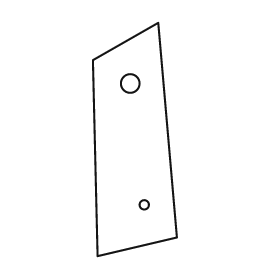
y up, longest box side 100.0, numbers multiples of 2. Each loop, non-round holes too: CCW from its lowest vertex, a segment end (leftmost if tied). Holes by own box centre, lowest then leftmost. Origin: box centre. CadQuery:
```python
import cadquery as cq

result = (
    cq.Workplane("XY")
    .moveTo(-16.0, -50.0)
    .lineTo(18.0, -42.0)
    .lineTo(10.0, 50.0)
    .lineTo(-18.0, 34.0)
    .close()
    .moveTo(4.0, -28.0)
    .circle(2.0)
    .moveTo(-2.0, 24.0)
    .circle(4.0)
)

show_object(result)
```